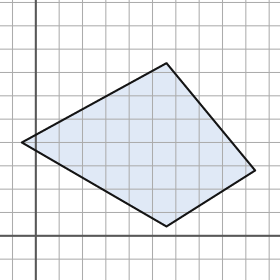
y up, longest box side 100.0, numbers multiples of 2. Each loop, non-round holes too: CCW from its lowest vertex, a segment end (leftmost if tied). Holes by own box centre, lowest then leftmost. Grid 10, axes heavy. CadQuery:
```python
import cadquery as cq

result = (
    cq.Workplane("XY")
    .moveTo(56.0, 4.0)
    .lineTo(94.0, 28.0)
    .lineTo(56.0, 74.0)
    .lineTo(-6.0, 40.0)
    .close()
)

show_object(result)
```